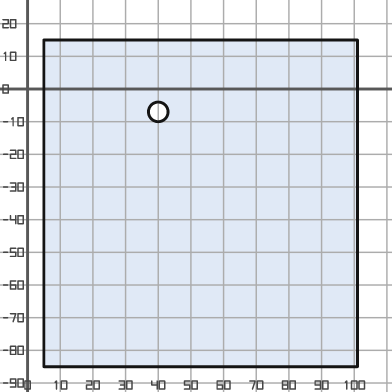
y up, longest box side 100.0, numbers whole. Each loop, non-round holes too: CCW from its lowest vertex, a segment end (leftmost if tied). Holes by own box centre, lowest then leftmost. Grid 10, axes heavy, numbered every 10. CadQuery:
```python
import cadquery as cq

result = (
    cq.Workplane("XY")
    .moveTo(5.0, -85.0)
    .lineTo(101.0, -85.0)
    .lineTo(101.0, 15.0)
    .lineTo(5.0, 15.0)
    .close()
    .moveTo(40.0, -7.0)
    .circle(3.0)
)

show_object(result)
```